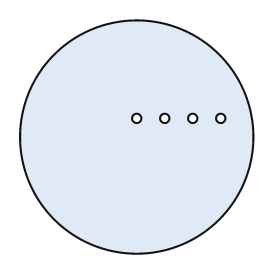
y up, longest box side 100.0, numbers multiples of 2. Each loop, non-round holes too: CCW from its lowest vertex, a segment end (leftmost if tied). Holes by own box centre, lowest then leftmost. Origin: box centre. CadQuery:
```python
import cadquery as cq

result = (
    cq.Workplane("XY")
    .moveTo(0.0, 0.0)
    .circle(50.0)
    .moveTo(0.0, 8.0)
    .circle(2.0)
    .moveTo(12.0, 8.0)
    .circle(2.0)
    .moveTo(24.0, 8.0)
    .circle(2.0)
    .moveTo(36.0, 8.0)
    .circle(2.0)
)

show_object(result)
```